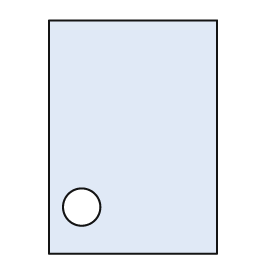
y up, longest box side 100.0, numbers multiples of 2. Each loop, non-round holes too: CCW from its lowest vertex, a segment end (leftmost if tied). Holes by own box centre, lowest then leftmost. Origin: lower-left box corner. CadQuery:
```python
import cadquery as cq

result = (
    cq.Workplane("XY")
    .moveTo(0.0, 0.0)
    .lineTo(72.0, 0.0)
    .lineTo(72.0, 100.0)
    .lineTo(0.0, 100.0)
    .close()
    .moveTo(14.0, 20.0)
    .circle(8.0)
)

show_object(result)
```